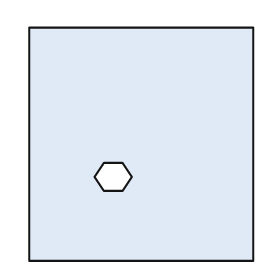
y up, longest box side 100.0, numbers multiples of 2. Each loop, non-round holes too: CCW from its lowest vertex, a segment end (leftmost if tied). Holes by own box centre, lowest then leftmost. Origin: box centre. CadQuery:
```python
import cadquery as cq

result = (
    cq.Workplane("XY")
    .moveTo(-48.0, -50.0)
    .lineTo(48.0, -50.0)
    .lineTo(48.0, 50.0)
    .lineTo(-48.0, 50.0)
    .close()
    .moveTo(-16.0, -20.0)
    .lineTo(-8.0, -20.0)
    .lineTo(-4.0, -14.0)
    .lineTo(-8.0, -8.0)
    .lineTo(-16.0, -8.0)
    .lineTo(-20.0, -14.0)
    .close()
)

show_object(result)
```